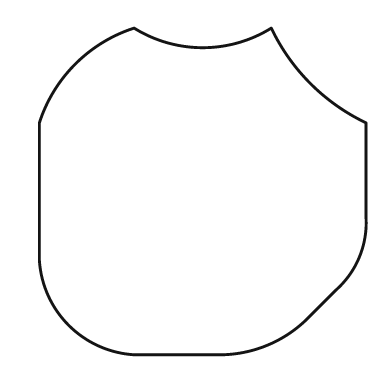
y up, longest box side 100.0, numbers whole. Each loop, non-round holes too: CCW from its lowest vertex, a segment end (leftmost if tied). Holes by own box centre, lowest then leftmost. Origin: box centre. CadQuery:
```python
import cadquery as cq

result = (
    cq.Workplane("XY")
    .moveTo(-21.0, -50.0)
    .lineTo(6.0, -50.0)
    .threePointArc((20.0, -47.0), (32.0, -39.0))
    .lineTo(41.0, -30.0)
    .threePointArc((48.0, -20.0), (50.0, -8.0))
    .lineTo(50.0, 21.0)
    .threePointArc((33.0, 33.0), (21.0, 50.0))
    .threePointArc((0.0, 44.0), (-21.0, 50.0))
    .threePointArc((-39.0, 39.0), (-50.0, 21.0))
    .lineTo(-50.0, -21.0)
    .threePointArc((-41.0, -41.0), (-21.0, -50.0))
    .close()
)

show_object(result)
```